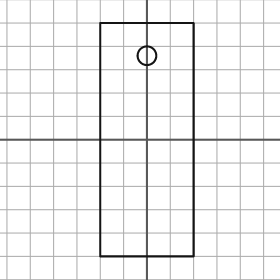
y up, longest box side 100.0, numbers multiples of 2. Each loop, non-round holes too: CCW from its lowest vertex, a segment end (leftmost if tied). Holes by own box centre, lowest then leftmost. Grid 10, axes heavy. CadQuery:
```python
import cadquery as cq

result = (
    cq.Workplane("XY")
    .moveTo(-20.0, -50.0)
    .lineTo(20.0, -50.0)
    .lineTo(20.0, 50.0)
    .lineTo(-20.0, 50.0)
    .close()
    .moveTo(0.0, 36.0)
    .circle(4.0)
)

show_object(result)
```